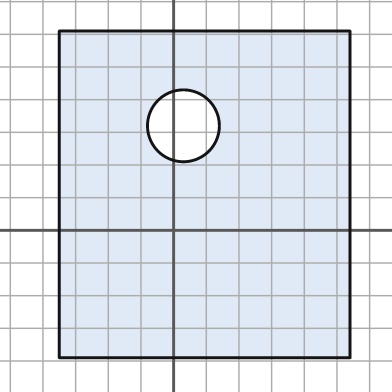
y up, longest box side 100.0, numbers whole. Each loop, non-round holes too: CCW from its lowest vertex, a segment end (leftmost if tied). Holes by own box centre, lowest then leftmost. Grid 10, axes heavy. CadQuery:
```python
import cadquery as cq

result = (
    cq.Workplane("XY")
    .moveTo(-35.0, -39.0)
    .lineTo(54.0, -39.0)
    .lineTo(54.0, 61.0)
    .lineTo(-35.0, 61.0)
    .close()
    .moveTo(3.0, 32.0)
    .circle(11.0)
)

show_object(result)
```